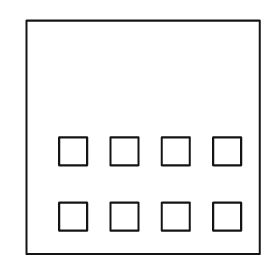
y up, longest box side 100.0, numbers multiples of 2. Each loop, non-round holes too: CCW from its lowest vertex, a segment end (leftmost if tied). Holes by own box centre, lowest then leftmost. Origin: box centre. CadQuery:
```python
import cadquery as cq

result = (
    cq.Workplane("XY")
    .moveTo(-50.0, -50.0)
    .lineTo(50.0, -50.0)
    .lineTo(50.0, 50.0)
    .lineTo(-50.0, 50.0)
    .close()
    .moveTo(-36.0, -40.0)
    .lineTo(-24.0, -40.0)
    .lineTo(-24.0, -28.0)
    .lineTo(-36.0, -28.0)
    .close()
    .moveTo(-14.0, -40.0)
    .lineTo(-2.0, -40.0)
    .lineTo(-2.0, -28.0)
    .lineTo(-14.0, -28.0)
    .close()
    .moveTo(8.0, -40.0)
    .lineTo(20.0, -40.0)
    .lineTo(20.0, -28.0)
    .lineTo(8.0, -28.0)
    .close()
    .moveTo(30.0, -40.0)
    .lineTo(42.0, -40.0)
    .lineTo(42.0, -28.0)
    .lineTo(30.0, -28.0)
    .close()
    .moveTo(-36.0, -12.0)
    .lineTo(-24.0, -12.0)
    .lineTo(-24.0, 0.0)
    .lineTo(-36.0, 0.0)
    .close()
    .moveTo(-14.0, -12.0)
    .lineTo(-2.0, -12.0)
    .lineTo(-2.0, 0.0)
    .lineTo(-14.0, 0.0)
    .close()
    .moveTo(8.0, -12.0)
    .lineTo(20.0, -12.0)
    .lineTo(20.0, 0.0)
    .lineTo(8.0, 0.0)
    .close()
    .moveTo(30.0, -12.0)
    .lineTo(42.0, -12.0)
    .lineTo(42.0, 0.0)
    .lineTo(30.0, 0.0)
    .close()
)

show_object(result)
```